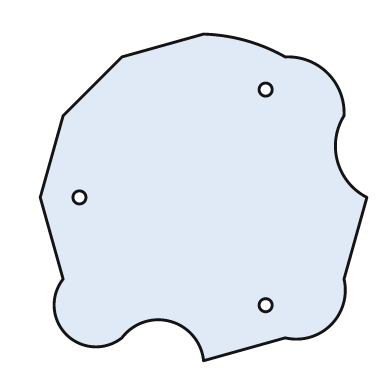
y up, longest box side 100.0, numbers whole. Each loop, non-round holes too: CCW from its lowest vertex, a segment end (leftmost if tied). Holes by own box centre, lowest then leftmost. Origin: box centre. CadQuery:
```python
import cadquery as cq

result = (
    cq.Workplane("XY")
    .moveTo(0.0, -50.0)
    .lineTo(25.0, -43.0)
    .threePointArc((39.0, -39.0), (43.0, -25.0))
    .lineTo(50.0, 0.0)
    .threePointArc((41.0, 11.0), (43.0, 25.0))
    .threePointArc((38.0, 38.0), (25.0, 43.0))
    .threePointArc((13.0, 48.0), (0.0, 50.0))
    .lineTo(-25.0, 43.0)
    .lineTo(-43.0, 25.0)
    .lineTo(-50.0, 0.0)
    .lineTo(-43.0, -25.0)
    .threePointArc((-42.0, -42.0), (-25.0, -43.0))
    .threePointArc((-10.0, -38.0), (0.0, -50.0))
    .close()
    .moveTo(19.0, -33.0)
    .circle(2.0)
    .moveTo(-38.0, 0.0)
    .circle(2.0)
    .moveTo(19.0, 33.0)
    .circle(2.0)
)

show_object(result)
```